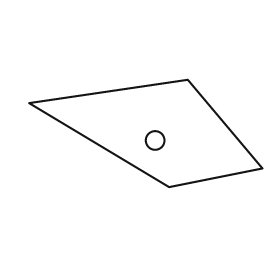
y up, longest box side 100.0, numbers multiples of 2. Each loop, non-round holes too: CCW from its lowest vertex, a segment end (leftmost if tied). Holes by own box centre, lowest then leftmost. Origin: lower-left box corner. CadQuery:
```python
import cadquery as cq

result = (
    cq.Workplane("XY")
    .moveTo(60.0, 0.0)
    .lineTo(100.0, 8.0)
    .lineTo(68.0, 46.0)
    .lineTo(0.0, 36.0)
    .close()
    .moveTo(54.0, 20.0)
    .circle(4.0)
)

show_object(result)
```